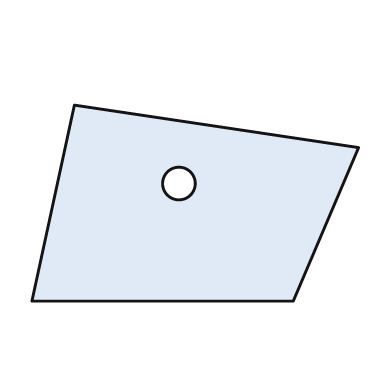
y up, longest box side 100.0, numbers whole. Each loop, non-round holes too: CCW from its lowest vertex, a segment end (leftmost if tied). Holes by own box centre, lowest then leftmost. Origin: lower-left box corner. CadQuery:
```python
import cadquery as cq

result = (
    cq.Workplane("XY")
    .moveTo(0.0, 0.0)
    .lineTo(80.0, 0.0)
    .lineTo(100.0, 47.0)
    .lineTo(13.0, 60.0)
    .close()
    .moveTo(45.0, 36.0)
    .circle(5.0)
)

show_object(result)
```